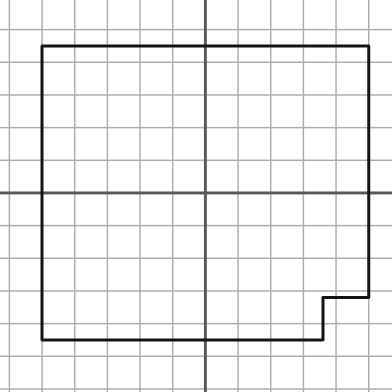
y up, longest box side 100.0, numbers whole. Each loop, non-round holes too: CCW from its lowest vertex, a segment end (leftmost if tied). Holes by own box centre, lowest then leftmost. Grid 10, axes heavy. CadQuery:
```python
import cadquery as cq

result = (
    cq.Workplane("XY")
    .moveTo(-50.0, -45.0)
    .lineTo(36.0, -45.0)
    .lineTo(36.0, -32.0)
    .lineTo(50.0, -32.0)
    .lineTo(50.0, 45.0)
    .lineTo(-50.0, 45.0)
    .close()
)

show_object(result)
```